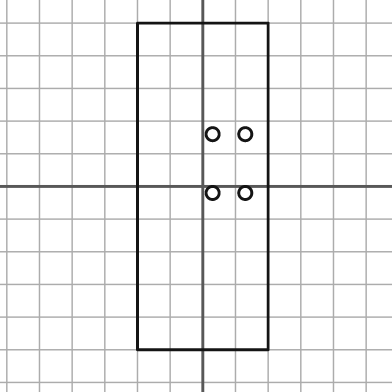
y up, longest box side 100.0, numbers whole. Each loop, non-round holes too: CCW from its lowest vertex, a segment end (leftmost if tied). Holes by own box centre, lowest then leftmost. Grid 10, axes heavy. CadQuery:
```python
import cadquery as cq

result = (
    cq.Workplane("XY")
    .moveTo(-20.0, -50.0)
    .lineTo(20.0, -50.0)
    .lineTo(20.0, 50.0)
    .lineTo(-20.0, 50.0)
    .close()
    .moveTo(3.0, -2.0)
    .circle(2.0)
    .moveTo(13.0, -2.0)
    .circle(2.0)
    .moveTo(3.0, 16.0)
    .circle(2.0)
    .moveTo(13.0, 16.0)
    .circle(2.0)
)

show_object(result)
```